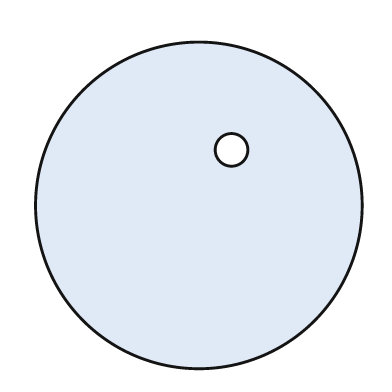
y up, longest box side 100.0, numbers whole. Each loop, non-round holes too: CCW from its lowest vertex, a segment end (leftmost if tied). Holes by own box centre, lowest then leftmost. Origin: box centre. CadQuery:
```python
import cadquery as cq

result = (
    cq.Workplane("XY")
    .moveTo(0.0, 0.0)
    .circle(50.0)
    .moveTo(10.0, 17.0)
    .circle(5.0)
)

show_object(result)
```